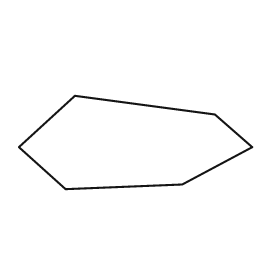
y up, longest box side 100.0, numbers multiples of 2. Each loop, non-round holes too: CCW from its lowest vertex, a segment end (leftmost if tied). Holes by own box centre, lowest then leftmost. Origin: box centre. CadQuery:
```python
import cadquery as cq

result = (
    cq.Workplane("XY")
    .moveTo(-30.0, -20.0)
    .lineTo(20.0, -18.0)
    .lineTo(50.0, -2.0)
    .lineTo(34.0, 12.0)
    .lineTo(-26.0, 20.0)
    .lineTo(-50.0, -2.0)
    .close()
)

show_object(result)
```